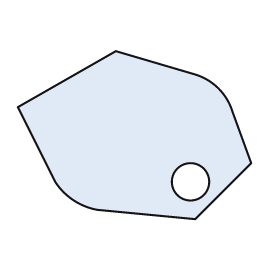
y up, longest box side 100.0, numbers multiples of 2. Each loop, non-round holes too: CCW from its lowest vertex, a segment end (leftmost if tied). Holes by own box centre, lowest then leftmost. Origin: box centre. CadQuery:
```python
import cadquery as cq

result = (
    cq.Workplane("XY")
    .moveTo(26.0, -36.0)
    .lineTo(50.0, -12.0)
    .lineTo(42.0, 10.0)
    .threePointArc((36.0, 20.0), (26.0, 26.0))
    .lineTo(-8.0, 36.0)
    .lineTo(-50.0, 12.0)
    .lineTo(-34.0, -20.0)
    .threePointArc((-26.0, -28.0), (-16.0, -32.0))
    .close()
    .moveTo(24.0, -20.0)
    .circle(8.0)
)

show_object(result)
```